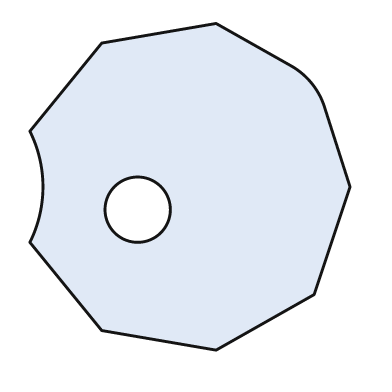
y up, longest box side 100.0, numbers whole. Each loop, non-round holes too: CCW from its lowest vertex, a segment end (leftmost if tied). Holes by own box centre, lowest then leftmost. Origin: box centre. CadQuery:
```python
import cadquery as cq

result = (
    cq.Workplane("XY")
    .moveTo(8.0, -50.0)
    .lineTo(38.0, -33.0)
    .lineTo(49.0, 0.0)
    .lineTo(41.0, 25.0)
    .threePointArc((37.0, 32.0), (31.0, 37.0))
    .lineTo(8.0, 50.0)
    .lineTo(-27.0, 44.0)
    .lineTo(-49.0, 17.0)
    .threePointArc((-45.0, 0.0), (-49.0, -17.0))
    .lineTo(-27.0, -44.0)
    .close()
    .moveTo(-16.0, -7.0)
    .circle(10.0)
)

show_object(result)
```